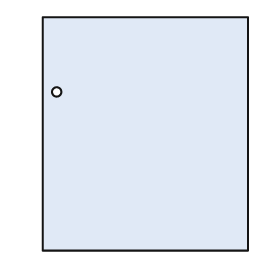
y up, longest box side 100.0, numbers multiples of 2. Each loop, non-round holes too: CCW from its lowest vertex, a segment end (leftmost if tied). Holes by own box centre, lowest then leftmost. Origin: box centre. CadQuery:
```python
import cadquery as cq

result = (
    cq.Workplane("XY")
    .moveTo(-44.0, -50.0)
    .lineTo(44.0, -50.0)
    .lineTo(44.0, 50.0)
    .lineTo(-44.0, 50.0)
    .close()
    .moveTo(-38.0, 18.0)
    .circle(2.0)
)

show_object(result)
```